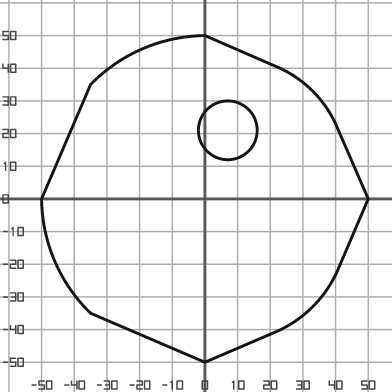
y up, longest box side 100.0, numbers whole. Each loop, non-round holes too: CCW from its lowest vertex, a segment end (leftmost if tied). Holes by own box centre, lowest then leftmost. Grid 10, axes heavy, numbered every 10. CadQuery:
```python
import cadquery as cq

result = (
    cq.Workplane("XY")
    .moveTo(0.0, -50.0)
    .lineTo(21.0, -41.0)
    .threePointArc((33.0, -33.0), (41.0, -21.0))
    .lineTo(50.0, 0.0)
    .lineTo(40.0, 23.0)
    .threePointArc((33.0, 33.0), (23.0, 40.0))
    .lineTo(0.0, 50.0)
    .threePointArc((-19.0, 46.0), (-35.0, 35.0))
    .lineTo(-50.0, 0.0)
    .threePointArc((-46.0, -19.0), (-35.0, -35.0))
    .close()
    .moveTo(7.0, 21.0)
    .circle(9.0)
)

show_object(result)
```